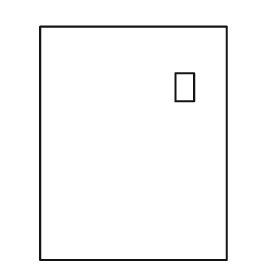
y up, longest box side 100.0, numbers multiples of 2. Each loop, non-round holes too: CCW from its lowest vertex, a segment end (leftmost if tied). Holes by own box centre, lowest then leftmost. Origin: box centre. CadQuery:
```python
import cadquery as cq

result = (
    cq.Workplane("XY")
    .moveTo(-40.0, -50.0)
    .lineTo(40.0, -50.0)
    .lineTo(40.0, 50.0)
    .lineTo(-40.0, 50.0)
    .close()
    .moveTo(18.0, 18.0)
    .lineTo(26.0, 18.0)
    .lineTo(26.0, 30.0)
    .lineTo(18.0, 30.0)
    .close()
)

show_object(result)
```